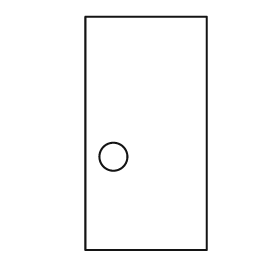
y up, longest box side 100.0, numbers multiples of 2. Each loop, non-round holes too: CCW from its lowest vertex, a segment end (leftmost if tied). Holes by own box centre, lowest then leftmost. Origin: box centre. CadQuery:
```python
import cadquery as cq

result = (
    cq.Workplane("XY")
    .moveTo(-26.0, -50.0)
    .lineTo(26.0, -50.0)
    .lineTo(26.0, 50.0)
    .lineTo(-26.0, 50.0)
    .close()
    .moveTo(-14.0, -10.0)
    .circle(6.0)
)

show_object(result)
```